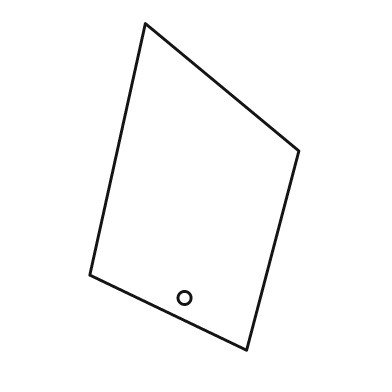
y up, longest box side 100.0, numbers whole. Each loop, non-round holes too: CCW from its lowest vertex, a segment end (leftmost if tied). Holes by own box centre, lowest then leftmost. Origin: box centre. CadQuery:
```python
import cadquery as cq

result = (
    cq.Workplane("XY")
    .moveTo(16.0, -50.0)
    .lineTo(32.0, 11.0)
    .lineTo(-15.0, 50.0)
    .lineTo(-32.0, -27.0)
    .close()
    .moveTo(-3.0, -34.0)
    .circle(2.0)
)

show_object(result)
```